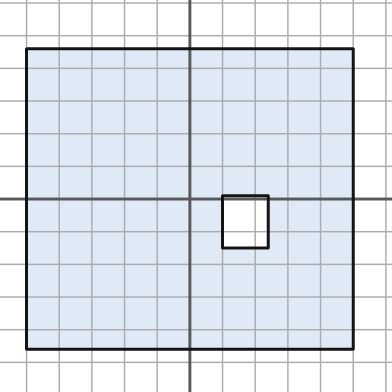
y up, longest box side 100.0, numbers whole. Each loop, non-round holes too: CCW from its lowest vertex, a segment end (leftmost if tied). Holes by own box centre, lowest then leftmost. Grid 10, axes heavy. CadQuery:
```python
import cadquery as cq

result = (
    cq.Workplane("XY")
    .moveTo(-50.0, -46.0)
    .lineTo(50.0, -46.0)
    .lineTo(50.0, 46.0)
    .lineTo(-50.0, 46.0)
    .close()
    .moveTo(10.0, -15.0)
    .lineTo(24.0, -15.0)
    .lineTo(24.0, 1.0)
    .lineTo(10.0, 1.0)
    .close()
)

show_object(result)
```